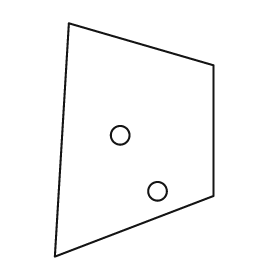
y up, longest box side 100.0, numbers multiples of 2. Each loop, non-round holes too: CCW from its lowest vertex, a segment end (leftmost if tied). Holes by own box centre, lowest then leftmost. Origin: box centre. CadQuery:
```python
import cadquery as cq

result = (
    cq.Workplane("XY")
    .moveTo(-34.0, -50.0)
    .lineTo(34.0, -24.0)
    .lineTo(34.0, 32.0)
    .lineTo(-28.0, 50.0)
    .close()
    .moveTo(10.0, -22.0)
    .circle(4.0)
    .moveTo(-6.0, 2.0)
    .circle(4.0)
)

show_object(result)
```